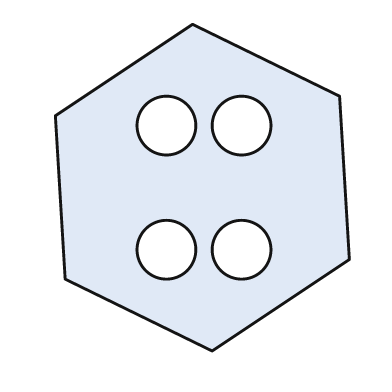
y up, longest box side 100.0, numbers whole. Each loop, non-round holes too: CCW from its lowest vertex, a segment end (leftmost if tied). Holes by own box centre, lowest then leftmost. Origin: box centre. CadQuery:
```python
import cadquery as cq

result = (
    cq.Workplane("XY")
    .moveTo(3.0, -50.0)
    .lineTo(45.0, -22.0)
    .lineTo(42.0, 28.0)
    .lineTo(-3.0, 50.0)
    .lineTo(-45.0, 22.0)
    .lineTo(-42.0, -28.0)
    .close()
    .moveTo(-11.0, -19.0)
    .circle(9.0)
    .moveTo(12.0, -19.0)
    .circle(9.0)
    .moveTo(-11.0, 19.0)
    .circle(9.0)
    .moveTo(12.0, 19.0)
    .circle(9.0)
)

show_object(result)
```